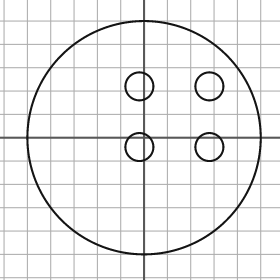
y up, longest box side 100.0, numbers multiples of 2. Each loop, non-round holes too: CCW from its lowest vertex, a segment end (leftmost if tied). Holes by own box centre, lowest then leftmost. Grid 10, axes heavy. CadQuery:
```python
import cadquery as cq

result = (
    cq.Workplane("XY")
    .moveTo(0.0, 0.0)
    .circle(50.0)
    .moveTo(-2.0, -4.0)
    .circle(6.0)
    .moveTo(28.0, -4.0)
    .circle(6.0)
    .moveTo(-2.0, 22.0)
    .circle(6.0)
    .moveTo(28.0, 22.0)
    .circle(6.0)
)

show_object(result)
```